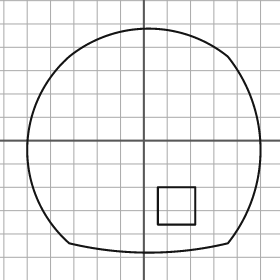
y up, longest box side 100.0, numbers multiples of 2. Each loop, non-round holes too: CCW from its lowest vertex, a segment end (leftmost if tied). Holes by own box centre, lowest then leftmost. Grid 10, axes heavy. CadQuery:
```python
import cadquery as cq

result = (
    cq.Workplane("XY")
    .moveTo(-32.0, -44.0)
    .threePointArc((2.0, -48.0), (36.0, -44.0))
    .threePointArc((50.0, -4.0), (36.0, 36.0))
    .threePointArc((2.0, 48.0), (-32.0, 36.0))
    .threePointArc((-50.0, -4.0), (-32.0, -44.0))
    .close()
    .moveTo(6.0, -36.0)
    .lineTo(22.0, -36.0)
    .lineTo(22.0, -20.0)
    .lineTo(6.0, -20.0)
    .close()
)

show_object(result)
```